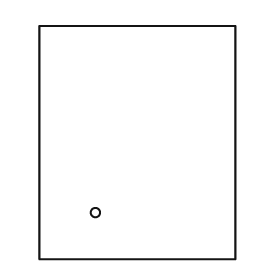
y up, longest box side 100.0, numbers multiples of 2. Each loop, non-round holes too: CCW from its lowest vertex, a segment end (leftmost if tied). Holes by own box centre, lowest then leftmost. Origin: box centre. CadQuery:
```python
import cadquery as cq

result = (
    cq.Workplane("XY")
    .moveTo(-42.0, -50.0)
    .lineTo(42.0, -50.0)
    .lineTo(42.0, 50.0)
    .lineTo(-42.0, 50.0)
    .close()
    .moveTo(-18.0, -30.0)
    .circle(2.0)
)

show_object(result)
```